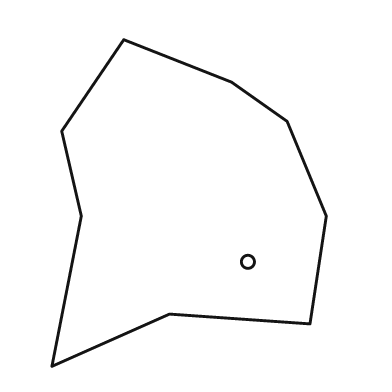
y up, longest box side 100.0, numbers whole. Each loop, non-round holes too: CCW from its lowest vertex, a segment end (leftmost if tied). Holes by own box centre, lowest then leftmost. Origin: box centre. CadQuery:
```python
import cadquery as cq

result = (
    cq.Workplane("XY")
    .moveTo(-42.0, -50.0)
    .lineTo(-6.0, -34.0)
    .lineTo(37.0, -37.0)
    .lineTo(42.0, -4.0)
    .lineTo(30.0, 25.0)
    .lineTo(13.0, 37.0)
    .lineTo(-20.0, 50.0)
    .lineTo(-39.0, 22.0)
    .lineTo(-33.0, -4.0)
    .close()
    .moveTo(18.0, -18.0)
    .circle(2.0)
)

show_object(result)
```